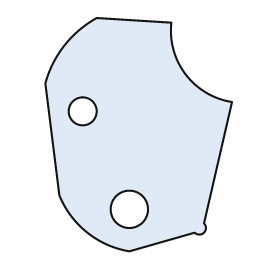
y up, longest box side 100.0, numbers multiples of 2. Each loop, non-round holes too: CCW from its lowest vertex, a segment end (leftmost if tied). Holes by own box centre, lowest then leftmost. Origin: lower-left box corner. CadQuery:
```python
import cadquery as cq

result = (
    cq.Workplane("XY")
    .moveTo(36.0, 0.0)
    .lineTo(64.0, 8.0)
    .threePointArc((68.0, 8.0), (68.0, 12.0))
    .lineTo(80.0, 64.0)
    .threePointArc((60.0, 76.0), (54.0, 98.0))
    .lineTo(22.0, 100.0)
    .threePointArc((8.0, 88.0), (0.0, 72.0))
    .lineTo(6.0, 24.0)
    .threePointArc((18.0, 8.0), (36.0, 0.0))
    .close()
    .moveTo(36.0, 18.0)
    .circle(8.0)
    .moveTo(16.0, 60.0)
    .circle(6.0)
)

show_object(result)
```